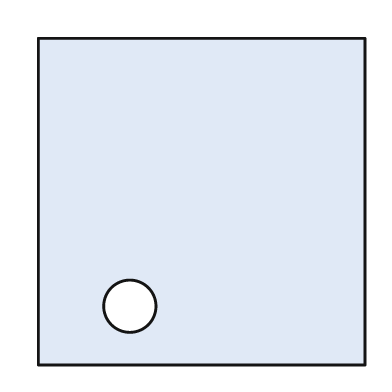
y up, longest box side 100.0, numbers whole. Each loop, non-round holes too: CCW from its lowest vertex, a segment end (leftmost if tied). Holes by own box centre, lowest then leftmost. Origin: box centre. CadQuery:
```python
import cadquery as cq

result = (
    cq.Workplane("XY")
    .moveTo(-50.0, -50.0)
    .lineTo(50.0, -50.0)
    .lineTo(50.0, 50.0)
    .lineTo(-50.0, 50.0)
    .close()
    .moveTo(-22.0, -32.0)
    .circle(8.0)
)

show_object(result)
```